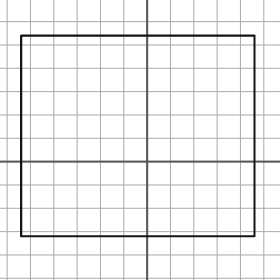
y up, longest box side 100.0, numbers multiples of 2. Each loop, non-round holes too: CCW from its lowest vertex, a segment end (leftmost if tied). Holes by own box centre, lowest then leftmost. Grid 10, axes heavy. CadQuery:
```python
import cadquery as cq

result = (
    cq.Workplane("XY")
    .moveTo(-54.0, -32.0)
    .lineTo(46.0, -32.0)
    .lineTo(46.0, 54.0)
    .lineTo(-54.0, 54.0)
    .close()
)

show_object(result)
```